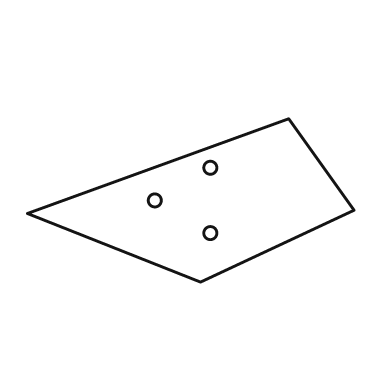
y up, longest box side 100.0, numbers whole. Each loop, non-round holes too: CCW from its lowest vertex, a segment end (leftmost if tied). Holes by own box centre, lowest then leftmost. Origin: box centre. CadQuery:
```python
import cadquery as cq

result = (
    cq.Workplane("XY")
    .moveTo(3.0, -25.0)
    .lineTo(50.0, -3.0)
    .lineTo(30.0, 25.0)
    .lineTo(-50.0, -4.0)
    .close()
    .moveTo(6.0, -10.0)
    .circle(2.0)
    .moveTo(-11.0, 0.0)
    .circle(2.0)
    .moveTo(6.0, 10.0)
    .circle(2.0)
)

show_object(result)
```